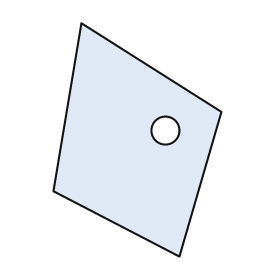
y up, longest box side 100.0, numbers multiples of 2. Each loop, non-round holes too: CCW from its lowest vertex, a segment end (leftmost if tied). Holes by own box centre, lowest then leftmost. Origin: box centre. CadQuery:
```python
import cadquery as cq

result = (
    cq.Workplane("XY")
    .moveTo(18.0, -50.0)
    .lineTo(36.0, 12.0)
    .lineTo(-24.0, 50.0)
    .lineTo(-36.0, -22.0)
    .close()
    .moveTo(12.0, 4.0)
    .circle(6.0)
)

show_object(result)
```